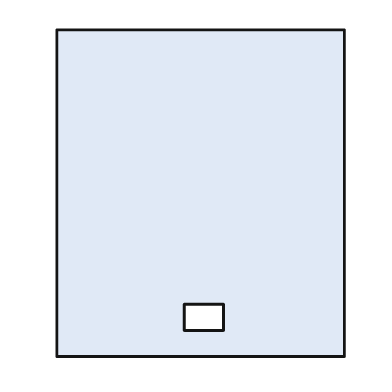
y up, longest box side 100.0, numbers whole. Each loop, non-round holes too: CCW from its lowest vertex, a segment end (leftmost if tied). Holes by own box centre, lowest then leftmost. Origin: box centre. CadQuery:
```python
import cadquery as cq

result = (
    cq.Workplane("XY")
    .moveTo(-44.0, -50.0)
    .lineTo(44.0, -50.0)
    .lineTo(44.0, 50.0)
    .lineTo(-44.0, 50.0)
    .close()
    .moveTo(-5.0, -42.0)
    .lineTo(7.0, -42.0)
    .lineTo(7.0, -34.0)
    .lineTo(-5.0, -34.0)
    .close()
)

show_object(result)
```